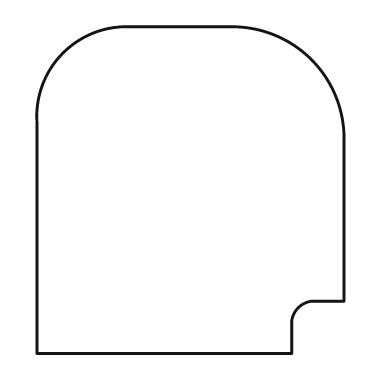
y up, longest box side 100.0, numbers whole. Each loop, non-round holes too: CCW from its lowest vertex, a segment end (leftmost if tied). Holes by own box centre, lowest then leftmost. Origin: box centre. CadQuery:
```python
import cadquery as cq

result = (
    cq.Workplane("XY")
    .moveTo(-47.0, -50.0)
    .lineTo(31.0, -50.0)
    .lineTo(31.0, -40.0)
    .threePointArc((33.0, -36.0), (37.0, -34.0))
    .lineTo(47.0, -34.0)
    .lineTo(47.0, 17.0)
    .threePointArc((37.0, 40.0), (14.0, 50.0))
    .lineTo(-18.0, 50.0)
    .threePointArc((-39.0, 42.0), (-47.0, 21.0))
    .close()
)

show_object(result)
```